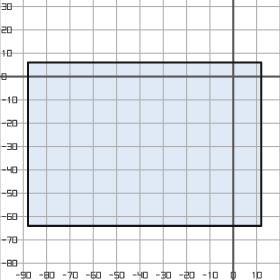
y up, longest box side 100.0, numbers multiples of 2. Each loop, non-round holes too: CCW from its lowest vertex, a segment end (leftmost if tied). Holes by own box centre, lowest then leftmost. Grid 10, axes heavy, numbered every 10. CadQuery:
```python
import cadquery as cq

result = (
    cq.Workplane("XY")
    .moveTo(-88.0, -64.0)
    .lineTo(12.0, -64.0)
    .lineTo(12.0, 6.0)
    .lineTo(-88.0, 6.0)
    .close()
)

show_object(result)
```